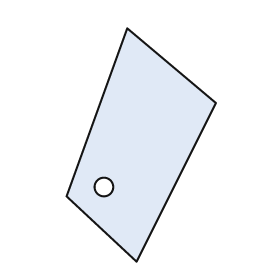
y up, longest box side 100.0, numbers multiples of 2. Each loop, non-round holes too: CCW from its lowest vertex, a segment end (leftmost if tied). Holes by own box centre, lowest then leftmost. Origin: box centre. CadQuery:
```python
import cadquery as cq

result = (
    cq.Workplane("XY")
    .moveTo(-2.0, -50.0)
    .lineTo(32.0, 18.0)
    .lineTo(-6.0, 50.0)
    .lineTo(-32.0, -22.0)
    .close()
    .moveTo(-16.0, -18.0)
    .circle(4.0)
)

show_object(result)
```